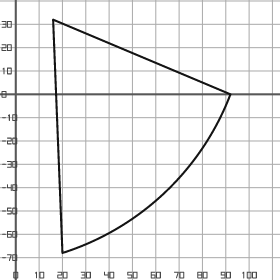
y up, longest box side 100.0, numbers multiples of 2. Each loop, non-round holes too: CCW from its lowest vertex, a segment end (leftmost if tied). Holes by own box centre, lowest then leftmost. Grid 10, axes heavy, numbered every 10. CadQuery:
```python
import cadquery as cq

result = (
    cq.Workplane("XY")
    .moveTo(20.0, -68.0)
    .threePointArc((64.0, -42.0), (92.0, 0.0))
    .lineTo(16.0, 32.0)
    .close()
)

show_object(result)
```